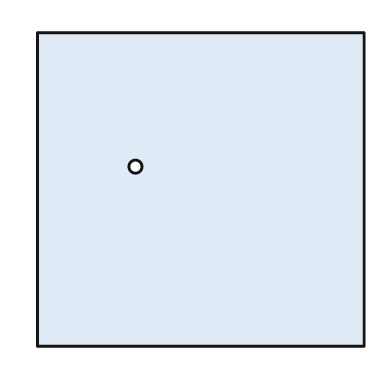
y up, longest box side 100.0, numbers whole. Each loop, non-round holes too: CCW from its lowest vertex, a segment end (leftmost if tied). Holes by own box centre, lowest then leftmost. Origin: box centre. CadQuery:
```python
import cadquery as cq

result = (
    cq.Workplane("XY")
    .moveTo(-50.0, -48.0)
    .lineTo(50.0, -48.0)
    .lineTo(50.0, 48.0)
    .lineTo(-50.0, 48.0)
    .close()
    .moveTo(-20.0, 7.0)
    .circle(2.0)
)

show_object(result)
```